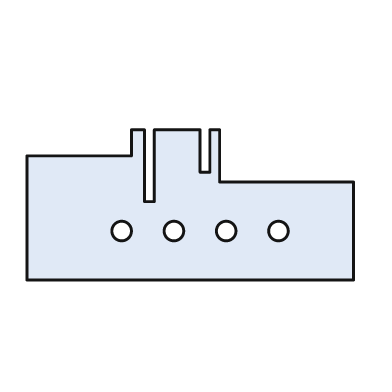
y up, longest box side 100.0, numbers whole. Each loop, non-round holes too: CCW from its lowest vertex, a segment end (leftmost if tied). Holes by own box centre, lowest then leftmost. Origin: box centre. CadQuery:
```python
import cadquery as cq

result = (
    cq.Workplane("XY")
    .moveTo(-50.0, -23.0)
    .lineTo(50.0, -23.0)
    .lineTo(50.0, 7.0)
    .lineTo(9.0, 7.0)
    .lineTo(9.0, 23.0)
    .lineTo(6.0, 23.0)
    .lineTo(6.0, 10.0)
    .lineTo(3.0, 10.0)
    .lineTo(3.0, 23.0)
    .lineTo(-11.0, 23.0)
    .lineTo(-11.0, 1.0)
    .lineTo(-14.0, 1.0)
    .lineTo(-14.0, 23.0)
    .lineTo(-18.0, 23.0)
    .lineTo(-18.0, 15.0)
    .lineTo(-50.0, 15.0)
    .close()
    .moveTo(-21.0, -8.0)
    .circle(3.0)
    .moveTo(-5.0, -8.0)
    .circle(3.0)
    .moveTo(11.0, -8.0)
    .circle(3.0)
    .moveTo(27.0, -8.0)
    .circle(3.0)
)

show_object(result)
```